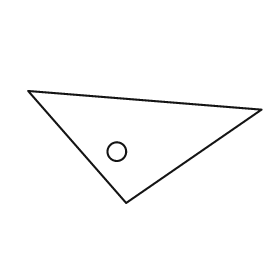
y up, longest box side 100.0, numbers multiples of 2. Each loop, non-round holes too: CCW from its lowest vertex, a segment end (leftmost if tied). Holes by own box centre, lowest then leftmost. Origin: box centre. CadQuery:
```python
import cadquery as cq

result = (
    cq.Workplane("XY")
    .moveTo(-8.0, -24.0)
    .lineTo(50.0, 16.0)
    .lineTo(-50.0, 24.0)
    .close()
    .moveTo(-12.0, -2.0)
    .circle(4.0)
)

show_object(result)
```